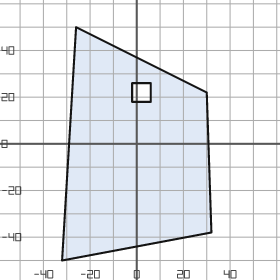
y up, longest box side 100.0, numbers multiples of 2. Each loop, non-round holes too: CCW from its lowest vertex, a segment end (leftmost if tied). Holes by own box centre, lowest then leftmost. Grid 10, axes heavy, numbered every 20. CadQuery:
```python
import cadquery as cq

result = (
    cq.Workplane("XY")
    .moveTo(-32.0, -50.0)
    .lineTo(32.0, -38.0)
    .lineTo(30.0, 22.0)
    .lineTo(-26.0, 50.0)
    .close()
    .moveTo(-2.0, 18.0)
    .lineTo(6.0, 18.0)
    .lineTo(6.0, 26.0)
    .lineTo(-2.0, 26.0)
    .close()
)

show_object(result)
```